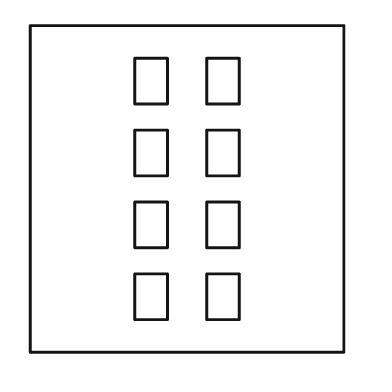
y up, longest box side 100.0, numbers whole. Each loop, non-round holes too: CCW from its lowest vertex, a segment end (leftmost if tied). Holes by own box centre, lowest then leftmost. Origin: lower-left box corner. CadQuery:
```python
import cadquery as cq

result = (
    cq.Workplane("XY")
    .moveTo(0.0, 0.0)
    .lineTo(96.0, 0.0)
    .lineTo(96.0, 100.0)
    .lineTo(0.0, 100.0)
    .close()
    .moveTo(32.0, 10.0)
    .lineTo(42.0, 10.0)
    .lineTo(42.0, 24.0)
    .lineTo(32.0, 24.0)
    .close()
    .moveTo(54.0, 10.0)
    .lineTo(64.0, 10.0)
    .lineTo(64.0, 24.0)
    .lineTo(54.0, 24.0)
    .close()
    .moveTo(32.0, 32.0)
    .lineTo(42.0, 32.0)
    .lineTo(42.0, 46.0)
    .lineTo(32.0, 46.0)
    .close()
    .moveTo(54.0, 32.0)
    .lineTo(64.0, 32.0)
    .lineTo(64.0, 46.0)
    .lineTo(54.0, 46.0)
    .close()
    .moveTo(32.0, 54.0)
    .lineTo(42.0, 54.0)
    .lineTo(42.0, 68.0)
    .lineTo(32.0, 68.0)
    .close()
    .moveTo(54.0, 54.0)
    .lineTo(64.0, 54.0)
    .lineTo(64.0, 68.0)
    .lineTo(54.0, 68.0)
    .close()
    .moveTo(32.0, 76.0)
    .lineTo(42.0, 76.0)
    .lineTo(42.0, 90.0)
    .lineTo(32.0, 90.0)
    .close()
    .moveTo(54.0, 76.0)
    .lineTo(64.0, 76.0)
    .lineTo(64.0, 90.0)
    .lineTo(54.0, 90.0)
    .close()
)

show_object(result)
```